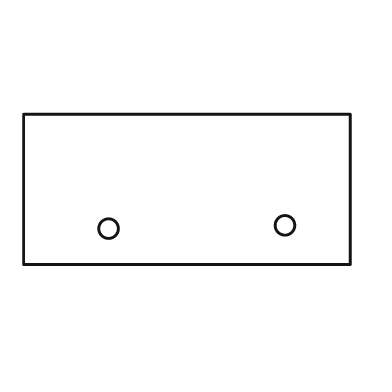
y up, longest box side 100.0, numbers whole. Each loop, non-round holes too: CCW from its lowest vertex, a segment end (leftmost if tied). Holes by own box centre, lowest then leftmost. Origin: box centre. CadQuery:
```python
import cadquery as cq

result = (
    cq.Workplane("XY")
    .moveTo(-50.0, -23.0)
    .lineTo(50.0, -23.0)
    .lineTo(50.0, 23.0)
    .lineTo(-50.0, 23.0)
    .close()
    .moveTo(-24.0, -12.0)
    .circle(3.0)
    .moveTo(30.0, -11.0)
    .circle(3.0)
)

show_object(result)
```